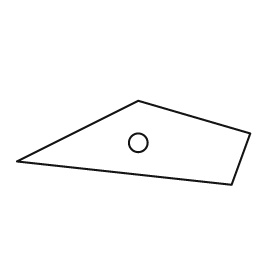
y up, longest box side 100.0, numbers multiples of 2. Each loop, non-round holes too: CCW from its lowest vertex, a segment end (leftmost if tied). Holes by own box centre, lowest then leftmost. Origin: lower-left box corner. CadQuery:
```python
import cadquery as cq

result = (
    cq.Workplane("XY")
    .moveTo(92.0, 0.0)
    .lineTo(100.0, 22.0)
    .lineTo(52.0, 36.0)
    .lineTo(0.0, 10.0)
    .close()
    .moveTo(52.0, 18.0)
    .circle(4.0)
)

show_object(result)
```